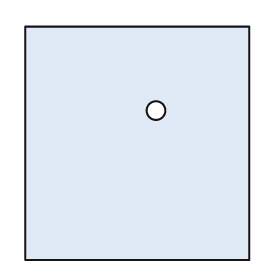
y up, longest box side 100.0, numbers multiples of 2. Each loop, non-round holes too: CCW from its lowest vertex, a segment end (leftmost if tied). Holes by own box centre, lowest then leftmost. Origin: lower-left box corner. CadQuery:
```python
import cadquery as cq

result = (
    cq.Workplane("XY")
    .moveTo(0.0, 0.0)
    .lineTo(96.0, 0.0)
    .lineTo(96.0, 100.0)
    .lineTo(0.0, 100.0)
    .close()
    .moveTo(56.0, 64.0)
    .circle(4.0)
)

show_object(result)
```